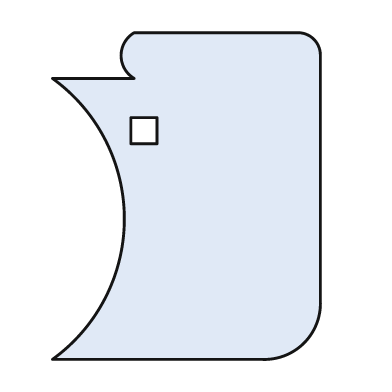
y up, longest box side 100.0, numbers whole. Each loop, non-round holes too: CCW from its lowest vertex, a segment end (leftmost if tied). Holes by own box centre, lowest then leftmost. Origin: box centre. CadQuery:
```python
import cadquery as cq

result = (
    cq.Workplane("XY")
    .moveTo(-41.0, -50.0)
    .lineTo(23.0, -50.0)
    .threePointArc((36.0, -45.0), (41.0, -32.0))
    .lineTo(41.0, 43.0)
    .threePointArc((39.0, 48.0), (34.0, 50.0))
    .lineTo(-16.0, 50.0)
    .threePointArc((-20.0, 43.0), (-16.0, 36.0))
    .lineTo(-41.0, 36.0)
    .threePointArc((-19.0, -7.0), (-41.0, -50.0))
    .close()
    .moveTo(-17.0, 16.0)
    .lineTo(-9.0, 16.0)
    .lineTo(-9.0, 24.0)
    .lineTo(-17.0, 24.0)
    .close()
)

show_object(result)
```